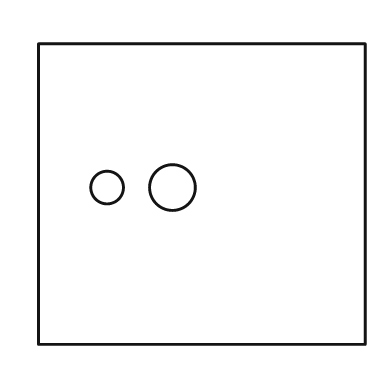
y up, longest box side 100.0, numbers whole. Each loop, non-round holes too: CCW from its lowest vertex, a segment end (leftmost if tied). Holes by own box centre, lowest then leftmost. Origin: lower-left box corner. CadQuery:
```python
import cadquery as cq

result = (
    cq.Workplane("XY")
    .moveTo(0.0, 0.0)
    .lineTo(100.0, 0.0)
    .lineTo(100.0, 92.0)
    .lineTo(0.0, 92.0)
    .close()
    .moveTo(21.0, 48.0)
    .circle(5.0)
    .moveTo(41.0, 48.0)
    .circle(7.0)
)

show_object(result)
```